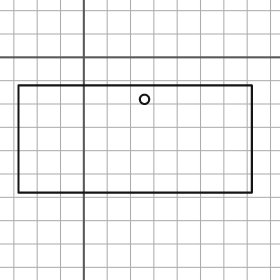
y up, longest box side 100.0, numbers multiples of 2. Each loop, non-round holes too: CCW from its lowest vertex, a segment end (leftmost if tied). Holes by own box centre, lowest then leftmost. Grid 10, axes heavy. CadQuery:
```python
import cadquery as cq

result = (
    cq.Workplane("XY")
    .moveTo(-28.0, -58.0)
    .lineTo(72.0, -58.0)
    .lineTo(72.0, -12.0)
    .lineTo(-28.0, -12.0)
    .close()
    .moveTo(26.0, -18.0)
    .circle(2.0)
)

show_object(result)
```